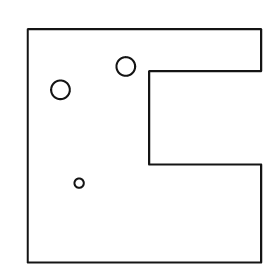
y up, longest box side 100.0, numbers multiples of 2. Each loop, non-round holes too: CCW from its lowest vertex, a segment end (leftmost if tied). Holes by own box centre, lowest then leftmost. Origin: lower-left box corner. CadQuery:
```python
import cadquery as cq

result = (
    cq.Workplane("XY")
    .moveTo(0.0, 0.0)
    .lineTo(100.0, 0.0)
    .lineTo(100.0, 42.0)
    .lineTo(52.0, 42.0)
    .lineTo(52.0, 82.0)
    .lineTo(100.0, 82.0)
    .lineTo(100.0, 100.0)
    .lineTo(0.0, 100.0)
    .close()
    .moveTo(22.0, 34.0)
    .circle(2.0)
    .moveTo(14.0, 74.0)
    .circle(4.0)
    .moveTo(42.0, 84.0)
    .circle(4.0)
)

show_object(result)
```